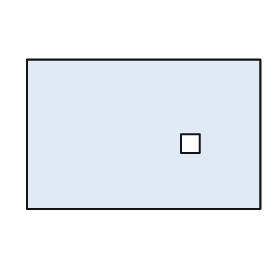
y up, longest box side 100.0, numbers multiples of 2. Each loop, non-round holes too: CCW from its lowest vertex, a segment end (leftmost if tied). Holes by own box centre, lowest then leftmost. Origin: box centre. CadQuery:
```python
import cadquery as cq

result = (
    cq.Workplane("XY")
    .moveTo(-50.0, -32.0)
    .lineTo(50.0, -32.0)
    .lineTo(50.0, 32.0)
    .lineTo(-50.0, 32.0)
    .close()
    .moveTo(16.0, -8.0)
    .lineTo(24.0, -8.0)
    .lineTo(24.0, 0.0)
    .lineTo(16.0, 0.0)
    .close()
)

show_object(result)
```